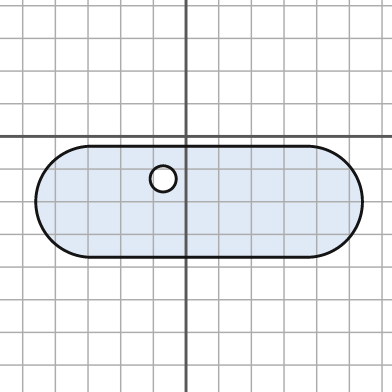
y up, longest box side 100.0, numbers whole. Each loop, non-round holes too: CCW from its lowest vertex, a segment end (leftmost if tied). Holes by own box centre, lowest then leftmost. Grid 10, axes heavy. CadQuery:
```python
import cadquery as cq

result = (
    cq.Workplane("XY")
    .moveTo(-29.0, -37.0)
    .lineTo(37.0, -37.0)
    .threePointArc((54.0, -20.0), (37.0, -3.0))
    .lineTo(-29.0, -3.0)
    .threePointArc((-46.0, -20.0), (-29.0, -37.0))
    .close()
    .moveTo(-7.0, -13.0)
    .circle(4.0)
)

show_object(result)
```